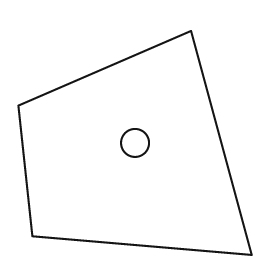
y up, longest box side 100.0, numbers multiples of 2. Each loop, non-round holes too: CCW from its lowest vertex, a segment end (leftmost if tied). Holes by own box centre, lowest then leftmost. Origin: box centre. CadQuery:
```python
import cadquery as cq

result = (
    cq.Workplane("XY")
    .moveTo(50.0, -48.0)
    .lineTo(24.0, 48.0)
    .lineTo(-50.0, 16.0)
    .lineTo(-44.0, -40.0)
    .close()
    .moveTo(0.0, 0.0)
    .circle(6.0)
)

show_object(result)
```